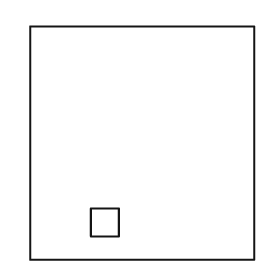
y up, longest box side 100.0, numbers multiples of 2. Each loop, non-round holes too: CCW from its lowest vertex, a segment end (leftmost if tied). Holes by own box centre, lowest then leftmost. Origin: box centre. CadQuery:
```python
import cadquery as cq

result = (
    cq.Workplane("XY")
    .moveTo(-48.0, -50.0)
    .lineTo(48.0, -50.0)
    .lineTo(48.0, 50.0)
    .lineTo(-48.0, 50.0)
    .close()
    .moveTo(-22.0, -40.0)
    .lineTo(-10.0, -40.0)
    .lineTo(-10.0, -28.0)
    .lineTo(-22.0, -28.0)
    .close()
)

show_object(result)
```